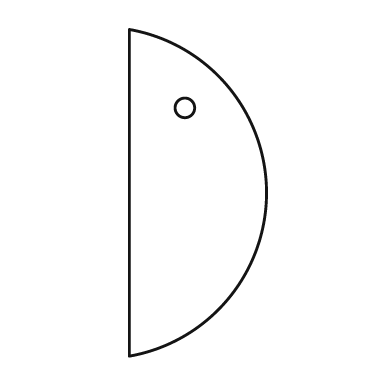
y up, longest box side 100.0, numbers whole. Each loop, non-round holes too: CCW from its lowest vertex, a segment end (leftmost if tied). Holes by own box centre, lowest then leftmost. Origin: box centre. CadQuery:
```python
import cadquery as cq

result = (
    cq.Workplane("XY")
    .moveTo(-21.0, -50.0)
    .threePointArc((21.0, 0.0), (-21.0, 50.0))
    .close()
    .moveTo(-4.0, 26.0)
    .circle(3.0)
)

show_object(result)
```